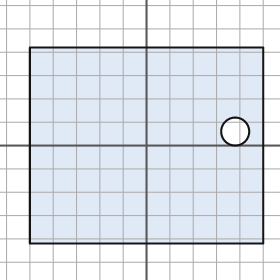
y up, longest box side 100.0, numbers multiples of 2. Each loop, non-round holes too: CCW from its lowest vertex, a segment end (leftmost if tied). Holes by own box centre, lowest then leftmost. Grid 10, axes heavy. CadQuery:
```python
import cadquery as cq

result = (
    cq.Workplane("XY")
    .moveTo(-50.0, -42.0)
    .lineTo(50.0, -42.0)
    .lineTo(50.0, 42.0)
    .lineTo(-50.0, 42.0)
    .close()
    .moveTo(38.0, 6.0)
    .circle(6.0)
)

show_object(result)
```